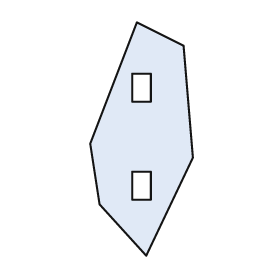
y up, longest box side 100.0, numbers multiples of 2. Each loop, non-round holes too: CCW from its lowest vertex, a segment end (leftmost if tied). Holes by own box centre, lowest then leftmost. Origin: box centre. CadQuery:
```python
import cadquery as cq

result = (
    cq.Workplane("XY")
    .moveTo(2.0, -50.0)
    .lineTo(22.0, -8.0)
    .lineTo(18.0, 40.0)
    .lineTo(-2.0, 50.0)
    .lineTo(-22.0, -2.0)
    .lineTo(-18.0, -28.0)
    .close()
    .moveTo(-4.0, -26.0)
    .lineTo(4.0, -26.0)
    .lineTo(4.0, -14.0)
    .lineTo(-4.0, -14.0)
    .close()
    .moveTo(-4.0, 16.0)
    .lineTo(4.0, 16.0)
    .lineTo(4.0, 28.0)
    .lineTo(-4.0, 28.0)
    .close()
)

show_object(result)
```